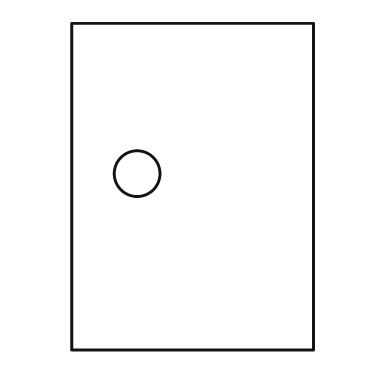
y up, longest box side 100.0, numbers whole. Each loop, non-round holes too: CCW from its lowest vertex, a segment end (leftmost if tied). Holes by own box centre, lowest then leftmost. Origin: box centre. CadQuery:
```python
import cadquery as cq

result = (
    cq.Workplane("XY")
    .moveTo(-37.0, -50.0)
    .lineTo(37.0, -50.0)
    .lineTo(37.0, 50.0)
    .lineTo(-37.0, 50.0)
    .close()
    .moveTo(-17.0, 4.0)
    .circle(7.0)
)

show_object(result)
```